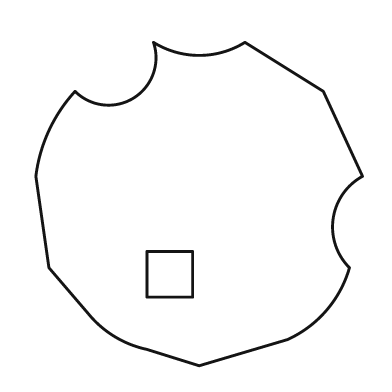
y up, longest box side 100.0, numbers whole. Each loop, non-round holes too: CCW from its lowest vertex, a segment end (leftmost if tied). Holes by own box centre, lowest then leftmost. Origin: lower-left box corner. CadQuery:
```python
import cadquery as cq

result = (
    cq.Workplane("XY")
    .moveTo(50.0, 0.0)
    .lineTo(77.0, 8.0)
    .threePointArc((89.0, 17.0), (96.0, 30.0))
    .threePointArc((91.0, 45.0), (100.0, 58.0))
    .lineTo(88.0, 84.0)
    .lineTo(64.0, 99.0)
    .threePointArc((50.0, 95.0), (36.0, 99.0))
    .threePointArc((30.0, 82.0), (12.0, 84.0))
    .threePointArc((4.0, 72.0), (0.0, 58.0))
    .lineTo(4.0, 30.0)
    .lineTo(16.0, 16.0)
    .threePointArc((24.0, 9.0), (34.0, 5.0))
    .close()
    .moveTo(34.0, 21.0)
    .lineTo(48.0, 21.0)
    .lineTo(48.0, 35.0)
    .lineTo(34.0, 35.0)
    .close()
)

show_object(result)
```